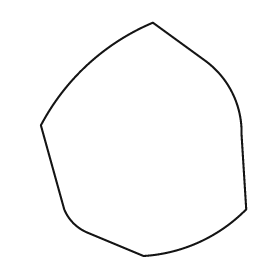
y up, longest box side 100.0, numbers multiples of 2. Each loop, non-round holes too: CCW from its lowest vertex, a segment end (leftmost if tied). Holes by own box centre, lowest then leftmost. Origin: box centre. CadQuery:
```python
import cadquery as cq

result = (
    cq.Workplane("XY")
    .moveTo(0.0, -50.0)
    .threePointArc((24.0, -44.0), (44.0, -30.0))
    .lineTo(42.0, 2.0)
    .threePointArc((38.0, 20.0), (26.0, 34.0))
    .lineTo(4.0, 50.0)
    .threePointArc((-24.0, 32.0), (-44.0, 6.0))
    .lineTo(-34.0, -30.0)
    .threePointArc((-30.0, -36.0), (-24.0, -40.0))
    .close()
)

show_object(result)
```